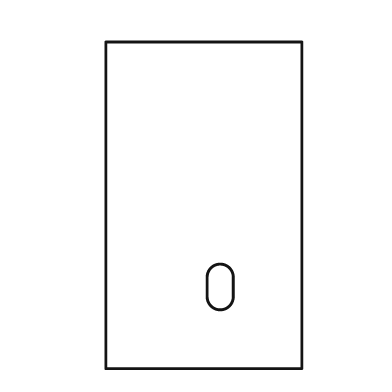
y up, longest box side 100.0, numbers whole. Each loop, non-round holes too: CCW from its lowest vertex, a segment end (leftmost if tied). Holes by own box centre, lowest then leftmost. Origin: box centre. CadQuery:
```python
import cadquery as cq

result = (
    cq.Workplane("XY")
    .moveTo(-30.0, -50.0)
    .lineTo(30.0, -50.0)
    .lineTo(30.0, 50.0)
    .lineTo(-30.0, 50.0)
    .close()
    .moveTo(1.0, -28.0)
    .threePointArc((5.0, -32.0), (9.0, -28.0))
    .lineTo(9.0, -22.0)
    .threePointArc((5.0, -18.0), (1.0, -22.0))
    .close()
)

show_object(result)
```